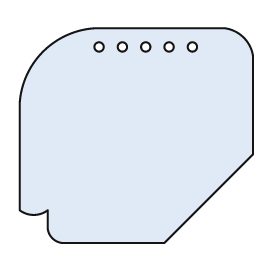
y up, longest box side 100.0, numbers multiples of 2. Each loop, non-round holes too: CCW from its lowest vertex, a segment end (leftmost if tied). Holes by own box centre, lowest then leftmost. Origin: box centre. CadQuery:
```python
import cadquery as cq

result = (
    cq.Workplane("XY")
    .moveTo(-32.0, -46.0)
    .lineTo(12.0, -46.0)
    .lineTo(50.0, -8.0)
    .lineTo(50.0, 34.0)
    .threePointArc((46.0, 42.0), (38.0, 46.0))
    .lineTo(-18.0, 46.0)
    .threePointArc((-40.0, 36.0), (-50.0, 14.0))
    .lineTo(-50.0, -32.0)
    .threePointArc((-44.0, -34.0), (-38.0, -32.0))
    .lineTo(-38.0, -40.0)
    .threePointArc((-36.0, -44.0), (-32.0, -46.0))
    .close()
    .moveTo(-16.0, 38.0)
    .circle(2.0)
    .moveTo(-6.0, 38.0)
    .circle(2.0)
    .moveTo(4.0, 38.0)
    .circle(2.0)
    .moveTo(14.0, 38.0)
    .circle(2.0)
    .moveTo(24.0, 38.0)
    .circle(2.0)
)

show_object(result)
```